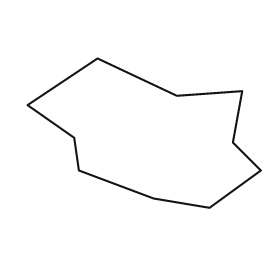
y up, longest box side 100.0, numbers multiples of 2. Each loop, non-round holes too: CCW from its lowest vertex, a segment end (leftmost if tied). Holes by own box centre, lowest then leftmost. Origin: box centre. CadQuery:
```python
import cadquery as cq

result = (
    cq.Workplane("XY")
    .moveTo(28.0, -32.0)
    .lineTo(50.0, -16.0)
    .lineTo(38.0, -4.0)
    .lineTo(42.0, 18.0)
    .lineTo(14.0, 16.0)
    .lineTo(-20.0, 32.0)
    .lineTo(-50.0, 12.0)
    .lineTo(-30.0, -2.0)
    .lineTo(-28.0, -16.0)
    .lineTo(4.0, -28.0)
    .close()
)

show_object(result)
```